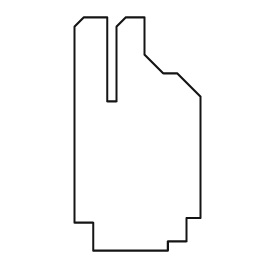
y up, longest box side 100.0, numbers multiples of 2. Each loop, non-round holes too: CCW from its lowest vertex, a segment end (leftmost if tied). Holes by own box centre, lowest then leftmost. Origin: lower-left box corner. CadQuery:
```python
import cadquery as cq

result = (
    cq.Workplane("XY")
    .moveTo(8.0, 0.0)
    .lineTo(40.0, 0.0)
    .lineTo(40.0, 4.0)
    .lineTo(48.0, 4.0)
    .lineTo(48.0, 14.0)
    .lineTo(54.0, 14.0)
    .lineTo(54.0, 66.0)
    .lineTo(44.0, 76.0)
    .lineTo(38.0, 76.0)
    .lineTo(30.0, 84.0)
    .lineTo(30.0, 100.0)
    .lineTo(22.0, 100.0)
    .lineTo(18.0, 96.0)
    .lineTo(18.0, 64.0)
    .lineTo(14.0, 64.0)
    .lineTo(14.0, 100.0)
    .lineTo(4.0, 100.0)
    .lineTo(0.0, 96.0)
    .lineTo(0.0, 12.0)
    .lineTo(8.0, 12.0)
    .close()
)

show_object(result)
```